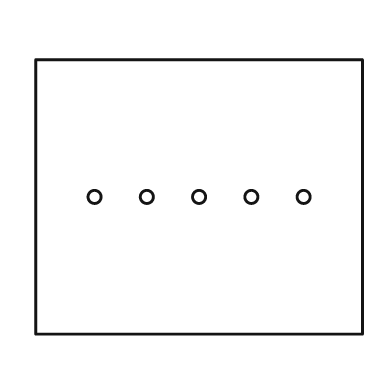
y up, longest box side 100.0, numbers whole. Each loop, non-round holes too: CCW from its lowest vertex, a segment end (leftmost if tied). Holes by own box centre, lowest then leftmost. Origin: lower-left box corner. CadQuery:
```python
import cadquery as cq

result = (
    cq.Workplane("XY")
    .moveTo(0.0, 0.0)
    .lineTo(100.0, 0.0)
    .lineTo(100.0, 84.0)
    .lineTo(0.0, 84.0)
    .close()
    .moveTo(18.0, 42.0)
    .circle(2.0)
    .moveTo(34.0, 42.0)
    .circle(2.0)
    .moveTo(50.0, 42.0)
    .circle(2.0)
    .moveTo(66.0, 42.0)
    .circle(2.0)
    .moveTo(82.0, 42.0)
    .circle(2.0)
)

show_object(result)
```